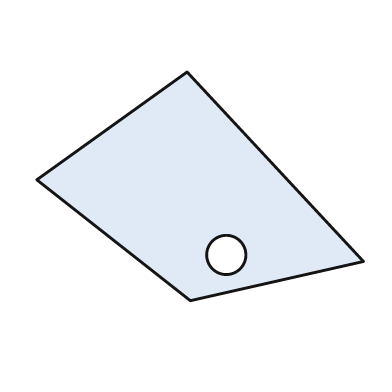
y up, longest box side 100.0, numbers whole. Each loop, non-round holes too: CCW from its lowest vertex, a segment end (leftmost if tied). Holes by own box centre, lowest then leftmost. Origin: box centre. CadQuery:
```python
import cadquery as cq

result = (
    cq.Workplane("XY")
    .moveTo(-3.0, -35.0)
    .lineTo(50.0, -23.0)
    .lineTo(-4.0, 35.0)
    .lineTo(-50.0, 2.0)
    .close()
    .moveTo(8.0, -21.0)
    .circle(6.0)
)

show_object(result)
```